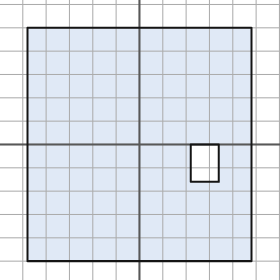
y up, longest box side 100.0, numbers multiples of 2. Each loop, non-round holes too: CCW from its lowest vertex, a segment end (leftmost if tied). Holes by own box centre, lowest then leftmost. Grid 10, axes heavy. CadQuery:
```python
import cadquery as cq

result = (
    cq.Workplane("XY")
    .moveTo(-48.0, -50.0)
    .lineTo(48.0, -50.0)
    .lineTo(48.0, 50.0)
    .lineTo(-48.0, 50.0)
    .close()
    .moveTo(22.0, -16.0)
    .lineTo(34.0, -16.0)
    .lineTo(34.0, 0.0)
    .lineTo(22.0, 0.0)
    .close()
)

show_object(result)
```